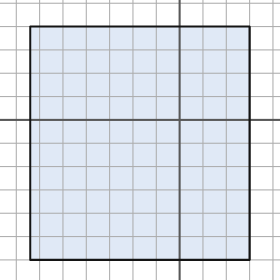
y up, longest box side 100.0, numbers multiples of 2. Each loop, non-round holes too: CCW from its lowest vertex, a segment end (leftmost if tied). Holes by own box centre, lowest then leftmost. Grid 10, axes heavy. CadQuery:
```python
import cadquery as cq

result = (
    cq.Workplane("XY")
    .moveTo(-64.0, -60.0)
    .lineTo(30.0, -60.0)
    .lineTo(30.0, 40.0)
    .lineTo(-64.0, 40.0)
    .close()
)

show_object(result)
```